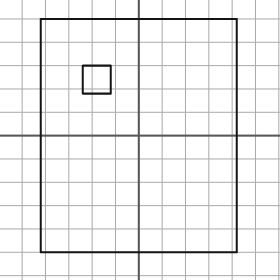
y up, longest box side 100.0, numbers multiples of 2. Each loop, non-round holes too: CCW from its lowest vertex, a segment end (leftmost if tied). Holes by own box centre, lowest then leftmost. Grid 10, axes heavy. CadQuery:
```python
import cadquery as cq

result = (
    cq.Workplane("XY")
    .moveTo(-42.0, -50.0)
    .lineTo(42.0, -50.0)
    .lineTo(42.0, 50.0)
    .lineTo(-42.0, 50.0)
    .close()
    .moveTo(-24.0, 18.0)
    .lineTo(-12.0, 18.0)
    .lineTo(-12.0, 30.0)
    .lineTo(-24.0, 30.0)
    .close()
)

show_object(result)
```